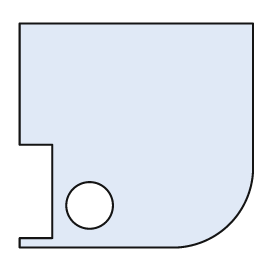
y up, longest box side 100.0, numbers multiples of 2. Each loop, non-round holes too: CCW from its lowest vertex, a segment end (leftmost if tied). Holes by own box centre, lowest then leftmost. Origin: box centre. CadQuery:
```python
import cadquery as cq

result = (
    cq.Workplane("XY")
    .moveTo(-50.0, -48.0)
    .lineTo(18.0, -48.0)
    .threePointArc((40.0, -38.0), (50.0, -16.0))
    .lineTo(50.0, 48.0)
    .lineTo(-50.0, 48.0)
    .lineTo(-50.0, -4.0)
    .lineTo(-36.0, -4.0)
    .lineTo(-36.0, -44.0)
    .lineTo(-50.0, -44.0)
    .close()
    .moveTo(-20.0, -30.0)
    .circle(10.0)
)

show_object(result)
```